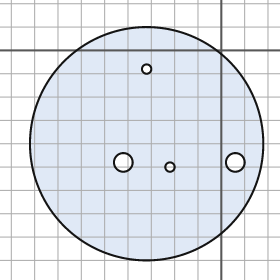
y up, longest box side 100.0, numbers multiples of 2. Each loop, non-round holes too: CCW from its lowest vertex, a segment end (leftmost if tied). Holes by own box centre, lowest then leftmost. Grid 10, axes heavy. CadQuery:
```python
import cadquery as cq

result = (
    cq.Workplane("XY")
    .moveTo(-32.0, -40.0)
    .circle(50.0)
    .moveTo(-22.0, -50.0)
    .circle(2.0)
    .moveTo(-42.0, -48.0)
    .circle(4.0)
    .moveTo(6.0, -48.0)
    .circle(4.0)
    .moveTo(-32.0, -8.0)
    .circle(2.0)
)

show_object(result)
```